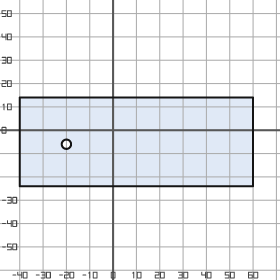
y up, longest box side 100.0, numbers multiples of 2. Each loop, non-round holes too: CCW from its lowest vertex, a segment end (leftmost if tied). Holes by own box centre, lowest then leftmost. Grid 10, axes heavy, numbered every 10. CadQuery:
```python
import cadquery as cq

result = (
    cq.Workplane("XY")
    .moveTo(-40.0, -24.0)
    .lineTo(60.0, -24.0)
    .lineTo(60.0, 14.0)
    .lineTo(-40.0, 14.0)
    .close()
    .moveTo(-20.0, -6.0)
    .circle(2.0)
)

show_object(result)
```